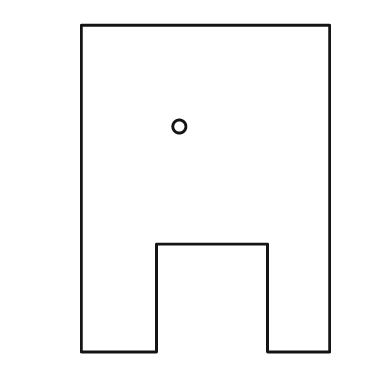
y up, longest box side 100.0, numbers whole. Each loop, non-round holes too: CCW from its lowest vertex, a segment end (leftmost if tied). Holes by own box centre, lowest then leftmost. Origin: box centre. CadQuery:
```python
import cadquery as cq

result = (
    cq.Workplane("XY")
    .moveTo(-38.0, -50.0)
    .lineTo(-15.0, -50.0)
    .lineTo(-15.0, -17.0)
    .lineTo(19.0, -17.0)
    .lineTo(19.0, -50.0)
    .lineTo(38.0, -50.0)
    .lineTo(38.0, 50.0)
    .lineTo(-38.0, 50.0)
    .close()
    .moveTo(-8.0, 19.0)
    .circle(2.0)
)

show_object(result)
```